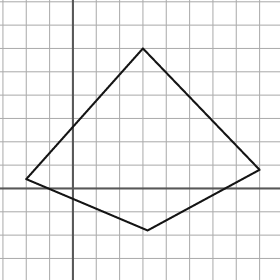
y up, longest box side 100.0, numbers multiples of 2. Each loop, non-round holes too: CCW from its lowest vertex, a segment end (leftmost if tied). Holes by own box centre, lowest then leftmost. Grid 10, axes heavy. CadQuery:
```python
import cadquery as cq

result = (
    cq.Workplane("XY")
    .moveTo(32.0, -18.0)
    .lineTo(80.0, 8.0)
    .lineTo(30.0, 60.0)
    .lineTo(-20.0, 4.0)
    .close()
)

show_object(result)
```